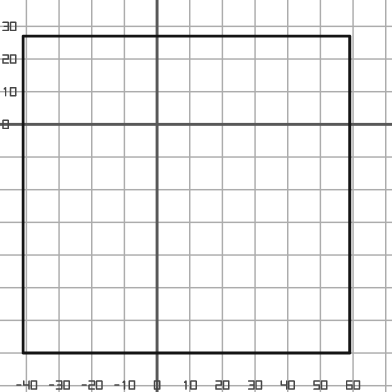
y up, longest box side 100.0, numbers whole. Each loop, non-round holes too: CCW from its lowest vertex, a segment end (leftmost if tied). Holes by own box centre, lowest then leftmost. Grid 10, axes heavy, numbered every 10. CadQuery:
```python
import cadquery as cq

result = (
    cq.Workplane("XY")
    .moveTo(-41.0, -70.0)
    .lineTo(59.0, -70.0)
    .lineTo(59.0, 27.0)
    .lineTo(-41.0, 27.0)
    .close()
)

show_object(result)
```